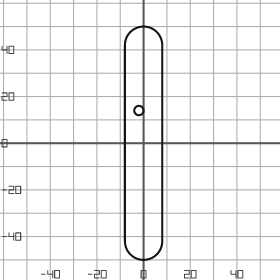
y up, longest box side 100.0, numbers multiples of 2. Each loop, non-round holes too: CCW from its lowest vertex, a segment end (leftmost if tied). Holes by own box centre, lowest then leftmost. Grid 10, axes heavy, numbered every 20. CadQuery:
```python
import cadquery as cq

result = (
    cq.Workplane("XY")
    .moveTo(-8.0, -42.0)
    .threePointArc((0.0, -50.0), (8.0, -42.0))
    .lineTo(8.0, 42.0)
    .threePointArc((0.0, 50.0), (-8.0, 42.0))
    .close()
    .moveTo(-2.0, 14.0)
    .circle(2.0)
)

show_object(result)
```